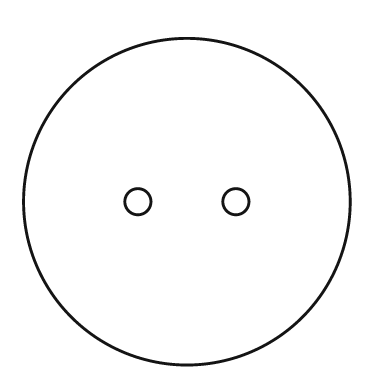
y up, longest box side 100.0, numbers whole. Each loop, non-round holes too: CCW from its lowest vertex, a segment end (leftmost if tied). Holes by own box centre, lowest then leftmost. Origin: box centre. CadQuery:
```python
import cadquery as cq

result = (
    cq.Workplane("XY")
    .moveTo(0.0, 0.0)
    .circle(50.0)
    .moveTo(-15.0, 0.0)
    .circle(4.0)
    .moveTo(15.0, 0.0)
    .circle(4.0)
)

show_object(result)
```